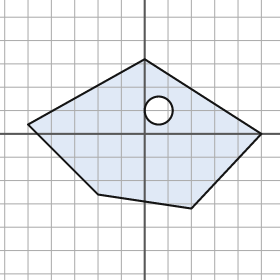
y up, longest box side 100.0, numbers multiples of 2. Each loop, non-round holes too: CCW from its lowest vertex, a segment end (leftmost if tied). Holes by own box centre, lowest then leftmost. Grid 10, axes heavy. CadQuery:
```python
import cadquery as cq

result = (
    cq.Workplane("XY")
    .moveTo(20.0, -32.0)
    .lineTo(50.0, 0.0)
    .lineTo(0.0, 32.0)
    .lineTo(-50.0, 4.0)
    .lineTo(-20.0, -26.0)
    .close()
    .moveTo(6.0, 10.0)
    .circle(6.0)
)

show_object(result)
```